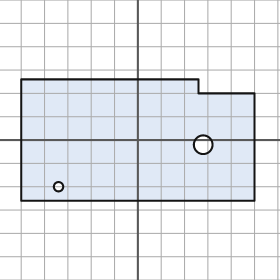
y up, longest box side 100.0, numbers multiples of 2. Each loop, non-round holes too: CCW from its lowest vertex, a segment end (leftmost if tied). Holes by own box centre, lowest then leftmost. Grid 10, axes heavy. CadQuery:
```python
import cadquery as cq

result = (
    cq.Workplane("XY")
    .moveTo(-50.0, -26.0)
    .lineTo(50.0, -26.0)
    .lineTo(50.0, 20.0)
    .lineTo(26.0, 20.0)
    .lineTo(26.0, 26.0)
    .lineTo(-50.0, 26.0)
    .close()
    .moveTo(-34.0, -20.0)
    .circle(2.0)
    .moveTo(28.0, -2.0)
    .circle(4.0)
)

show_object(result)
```